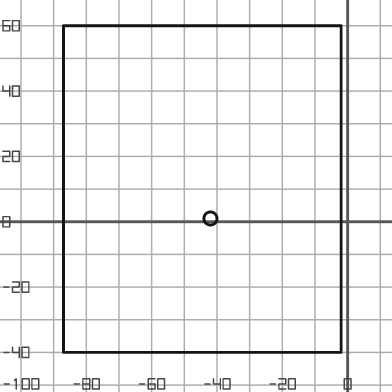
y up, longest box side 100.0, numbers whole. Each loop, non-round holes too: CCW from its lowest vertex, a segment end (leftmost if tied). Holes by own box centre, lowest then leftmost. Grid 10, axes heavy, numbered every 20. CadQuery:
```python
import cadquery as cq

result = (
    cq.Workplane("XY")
    .moveTo(-87.0, -40.0)
    .lineTo(-2.0, -40.0)
    .lineTo(-2.0, 60.0)
    .lineTo(-87.0, 60.0)
    .close()
    .moveTo(-42.0, 1.0)
    .circle(2.0)
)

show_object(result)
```